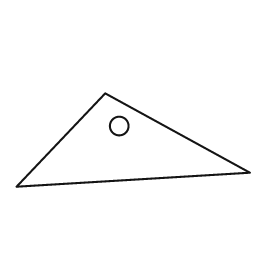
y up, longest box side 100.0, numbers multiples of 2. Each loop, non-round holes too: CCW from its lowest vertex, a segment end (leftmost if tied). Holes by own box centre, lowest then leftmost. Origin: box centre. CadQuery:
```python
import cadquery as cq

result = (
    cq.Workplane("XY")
    .moveTo(-50.0, -20.0)
    .lineTo(50.0, -14.0)
    .lineTo(-12.0, 20.0)
    .close()
    .moveTo(-6.0, 6.0)
    .circle(4.0)
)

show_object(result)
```